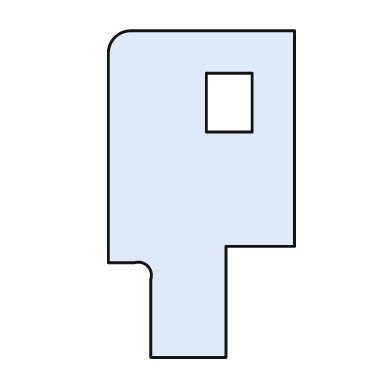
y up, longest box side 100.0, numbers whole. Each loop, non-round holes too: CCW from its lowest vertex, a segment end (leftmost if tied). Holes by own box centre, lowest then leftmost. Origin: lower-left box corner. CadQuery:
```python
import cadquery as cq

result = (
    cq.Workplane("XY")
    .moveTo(13.0, 0.0)
    .lineTo(36.0, 0.0)
    .lineTo(36.0, 34.0)
    .lineTo(57.0, 34.0)
    .lineTo(57.0, 100.0)
    .lineTo(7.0, 100.0)
    .threePointArc((2.0, 98.0), (0.0, 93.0))
    .lineTo(0.0, 29.0)
    .lineTo(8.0, 29.0)
    .threePointArc((12.0, 28.0), (13.0, 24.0))
    .close()
    .moveTo(30.0, 69.0)
    .lineTo(44.0, 69.0)
    .lineTo(44.0, 87.0)
    .lineTo(30.0, 87.0)
    .close()
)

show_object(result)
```